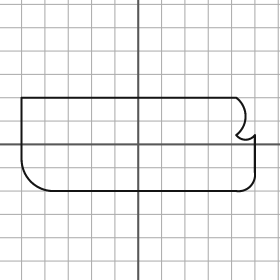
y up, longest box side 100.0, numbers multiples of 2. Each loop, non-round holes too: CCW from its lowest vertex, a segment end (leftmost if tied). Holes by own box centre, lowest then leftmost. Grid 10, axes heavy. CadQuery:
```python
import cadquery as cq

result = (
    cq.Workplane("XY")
    .moveTo(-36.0, -20.0)
    .lineTo(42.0, -20.0)
    .threePointArc((48.0, -18.0), (50.0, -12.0))
    .lineTo(50.0, 4.0)
    .threePointArc((46.0, 2.0), (42.0, 4.0))
    .threePointArc((46.0, 12.0), (42.0, 20.0))
    .lineTo(-50.0, 20.0)
    .lineTo(-50.0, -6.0)
    .threePointArc((-46.0, -16.0), (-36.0, -20.0))
    .close()
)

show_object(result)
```